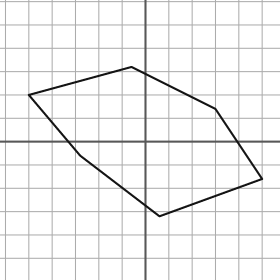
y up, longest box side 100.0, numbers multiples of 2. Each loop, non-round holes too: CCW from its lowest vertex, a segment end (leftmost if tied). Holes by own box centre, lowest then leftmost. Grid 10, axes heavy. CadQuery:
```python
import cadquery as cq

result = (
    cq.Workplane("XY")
    .moveTo(6.0, -32.0)
    .lineTo(50.0, -16.0)
    .lineTo(30.0, 14.0)
    .lineTo(-6.0, 32.0)
    .lineTo(-50.0, 20.0)
    .lineTo(-28.0, -6.0)
    .close()
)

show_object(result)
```